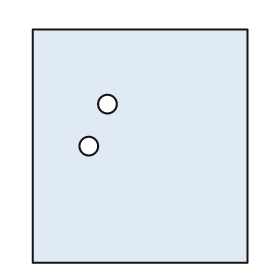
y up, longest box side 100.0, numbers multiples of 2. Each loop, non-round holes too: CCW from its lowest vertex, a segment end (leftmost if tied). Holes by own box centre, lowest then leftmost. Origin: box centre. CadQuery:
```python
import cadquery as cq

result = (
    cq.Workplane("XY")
    .moveTo(-46.0, -50.0)
    .lineTo(46.0, -50.0)
    .lineTo(46.0, 50.0)
    .lineTo(-46.0, 50.0)
    .close()
    .moveTo(-22.0, 0.0)
    .circle(4.0)
    .moveTo(-14.0, 18.0)
    .circle(4.0)
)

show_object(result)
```